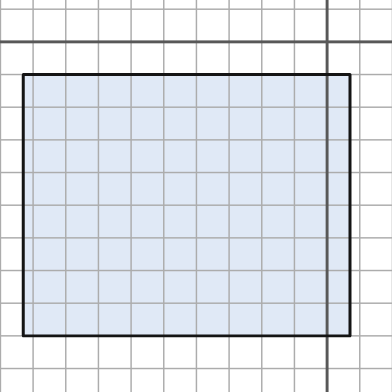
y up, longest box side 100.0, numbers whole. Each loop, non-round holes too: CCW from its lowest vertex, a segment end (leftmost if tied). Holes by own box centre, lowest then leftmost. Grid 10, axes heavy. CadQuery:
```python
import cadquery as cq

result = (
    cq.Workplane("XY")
    .moveTo(-93.0, -90.0)
    .lineTo(7.0, -90.0)
    .lineTo(7.0, -10.0)
    .lineTo(-93.0, -10.0)
    .close()
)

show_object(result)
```